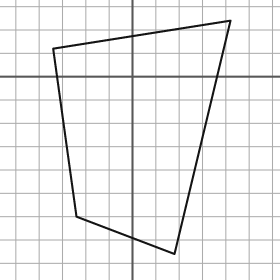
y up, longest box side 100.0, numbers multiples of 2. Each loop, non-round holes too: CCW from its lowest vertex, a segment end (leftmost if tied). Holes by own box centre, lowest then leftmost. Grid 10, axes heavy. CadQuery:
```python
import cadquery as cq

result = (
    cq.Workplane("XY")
    .moveTo(18.0, -76.0)
    .lineTo(42.0, 24.0)
    .lineTo(-34.0, 12.0)
    .lineTo(-24.0, -60.0)
    .close()
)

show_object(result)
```